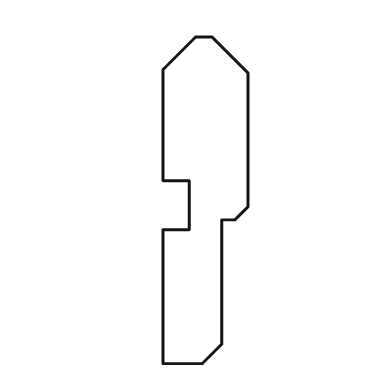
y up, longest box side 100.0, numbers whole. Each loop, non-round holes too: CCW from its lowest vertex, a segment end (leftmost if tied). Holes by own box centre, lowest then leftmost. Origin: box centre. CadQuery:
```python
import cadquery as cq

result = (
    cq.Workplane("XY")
    .moveTo(-13.0, -50.0)
    .lineTo(-1.0, -50.0)
    .lineTo(5.0, -44.0)
    .lineTo(5.0, -6.0)
    .lineTo(9.0, -6.0)
    .lineTo(13.0, -2.0)
    .lineTo(13.0, 39.0)
    .lineTo(2.0, 50.0)
    .lineTo(-3.0, 50.0)
    .lineTo(-13.0, 40.0)
    .lineTo(-13.0, 6.0)
    .lineTo(-5.0, 6.0)
    .lineTo(-5.0, -9.0)
    .lineTo(-13.0, -9.0)
    .close()
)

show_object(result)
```